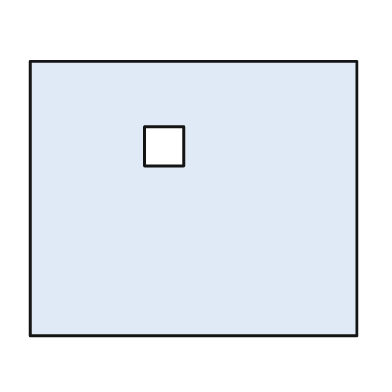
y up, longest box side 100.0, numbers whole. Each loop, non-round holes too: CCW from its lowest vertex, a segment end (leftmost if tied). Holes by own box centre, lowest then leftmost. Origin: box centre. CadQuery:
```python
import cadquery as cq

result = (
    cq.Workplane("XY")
    .moveTo(-50.0, -42.0)
    .lineTo(50.0, -42.0)
    .lineTo(50.0, 42.0)
    .lineTo(-50.0, 42.0)
    .close()
    .moveTo(-15.0, 10.0)
    .lineTo(-3.0, 10.0)
    .lineTo(-3.0, 22.0)
    .lineTo(-15.0, 22.0)
    .close()
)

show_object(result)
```